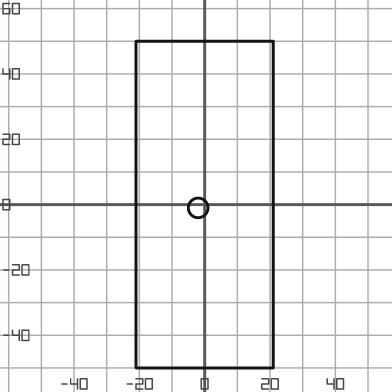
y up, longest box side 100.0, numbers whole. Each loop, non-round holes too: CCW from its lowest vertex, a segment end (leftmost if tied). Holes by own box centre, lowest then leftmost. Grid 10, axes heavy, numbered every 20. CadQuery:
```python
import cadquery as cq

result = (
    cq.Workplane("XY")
    .moveTo(-21.0, -50.0)
    .lineTo(21.0, -50.0)
    .lineTo(21.0, 50.0)
    .lineTo(-21.0, 50.0)
    .close()
    .moveTo(-2.0, -1.0)
    .circle(3.0)
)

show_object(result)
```